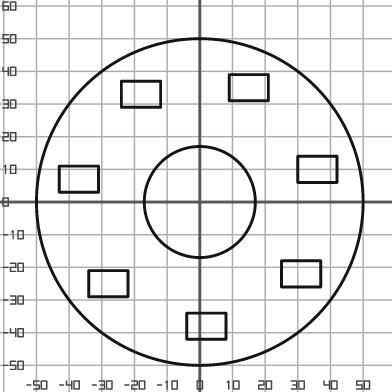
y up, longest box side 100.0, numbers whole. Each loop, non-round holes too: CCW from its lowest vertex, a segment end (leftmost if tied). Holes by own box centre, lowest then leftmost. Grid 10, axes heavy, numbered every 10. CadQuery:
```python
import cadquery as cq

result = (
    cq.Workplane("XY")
    .moveTo(0.0, 0.0)
    .circle(50.0)
    .moveTo(-4.0, -42.0)
    .lineTo(8.0, -42.0)
    .lineTo(8.0, -34.0)
    .lineTo(-4.0, -34.0)
    .close()
    .moveTo(-34.0, -29.0)
    .lineTo(-22.0, -29.0)
    .lineTo(-22.0, -21.0)
    .lineTo(-34.0, -21.0)
    .close()
    .moveTo(25.0, -26.0)
    .lineTo(37.0, -26.0)
    .lineTo(37.0, -18.0)
    .lineTo(25.0, -18.0)
    .close()
    .moveTo(0.0, 0.0)
    .circle(17.0)
    .moveTo(-43.0, 3.0)
    .lineTo(-31.0, 3.0)
    .lineTo(-31.0, 11.0)
    .lineTo(-43.0, 11.0)
    .close()
    .moveTo(30.0, 6.0)
    .lineTo(42.0, 6.0)
    .lineTo(42.0, 14.0)
    .lineTo(30.0, 14.0)
    .close()
    .moveTo(-24.0, 29.0)
    .lineTo(-12.0, 29.0)
    .lineTo(-12.0, 37.0)
    .lineTo(-24.0, 37.0)
    .close()
    .moveTo(9.0, 31.0)
    .lineTo(21.0, 31.0)
    .lineTo(21.0, 39.0)
    .lineTo(9.0, 39.0)
    .close()
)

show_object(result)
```